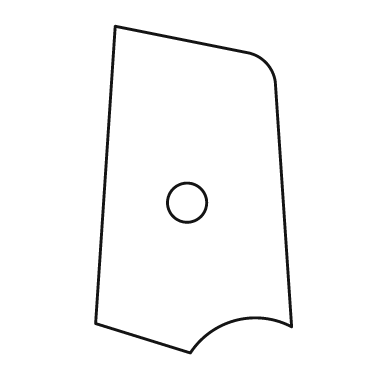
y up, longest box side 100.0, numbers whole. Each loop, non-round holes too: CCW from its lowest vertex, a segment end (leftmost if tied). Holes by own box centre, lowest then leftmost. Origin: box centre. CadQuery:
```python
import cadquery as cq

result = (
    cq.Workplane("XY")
    .moveTo(-1.0, -50.0)
    .threePointArc((13.0, -40.0), (30.0, -42.0))
    .lineTo(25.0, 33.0)
    .threePointArc((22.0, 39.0), (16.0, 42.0))
    .lineTo(-24.0, 50.0)
    .lineTo(-30.0, -41.0)
    .close()
    .moveTo(-2.0, -4.0)
    .circle(6.0)
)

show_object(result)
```